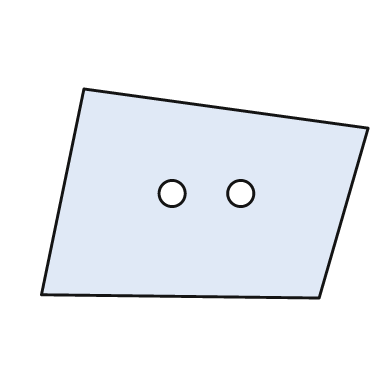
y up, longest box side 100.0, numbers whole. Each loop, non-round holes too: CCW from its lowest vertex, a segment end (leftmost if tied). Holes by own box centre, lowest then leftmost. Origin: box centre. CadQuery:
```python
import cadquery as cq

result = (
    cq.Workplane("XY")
    .moveTo(35.0, -32.0)
    .lineTo(50.0, 20.0)
    .lineTo(-37.0, 32.0)
    .lineTo(-50.0, -31.0)
    .close()
    .moveTo(-10.0, 0.0)
    .circle(4.0)
    .moveTo(11.0, 0.0)
    .circle(4.0)
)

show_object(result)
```